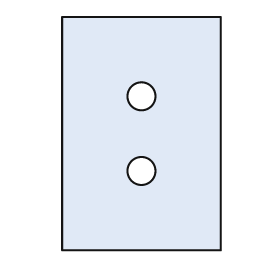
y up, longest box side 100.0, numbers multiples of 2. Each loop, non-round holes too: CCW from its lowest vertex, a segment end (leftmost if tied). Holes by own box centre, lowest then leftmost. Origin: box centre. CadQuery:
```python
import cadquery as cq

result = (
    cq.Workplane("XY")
    .moveTo(-34.0, -50.0)
    .lineTo(34.0, -50.0)
    .lineTo(34.0, 50.0)
    .lineTo(-34.0, 50.0)
    .close()
    .moveTo(0.0, -16.0)
    .circle(6.0)
    .moveTo(0.0, 16.0)
    .circle(6.0)
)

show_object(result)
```